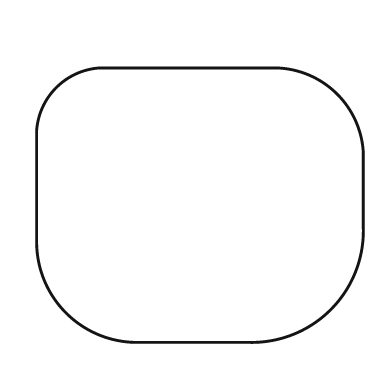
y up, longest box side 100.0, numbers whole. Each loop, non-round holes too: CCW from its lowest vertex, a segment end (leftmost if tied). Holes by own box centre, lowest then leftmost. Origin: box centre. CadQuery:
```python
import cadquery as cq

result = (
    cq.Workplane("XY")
    .moveTo(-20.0, -42.0)
    .lineTo(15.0, -42.0)
    .threePointArc((40.0, -32.0), (50.0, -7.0))
    .lineTo(50.0, 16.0)
    .threePointArc((42.0, 34.0), (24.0, 42.0))
    .lineTo(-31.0, 42.0)
    .threePointArc((-44.0, 36.0), (-50.0, 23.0))
    .lineTo(-50.0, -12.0)
    .threePointArc((-41.0, -33.0), (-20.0, -42.0))
    .close()
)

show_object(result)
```